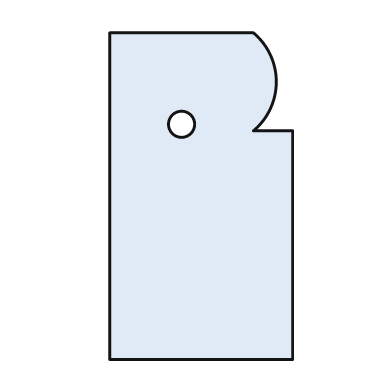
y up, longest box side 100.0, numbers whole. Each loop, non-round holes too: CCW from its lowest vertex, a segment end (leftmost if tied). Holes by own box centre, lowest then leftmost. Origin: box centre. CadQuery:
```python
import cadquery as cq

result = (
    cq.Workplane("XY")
    .moveTo(-28.0, -50.0)
    .lineTo(28.0, -50.0)
    .lineTo(28.0, 20.0)
    .lineTo(16.0, 20.0)
    .threePointArc((23.0, 35.0), (16.0, 50.0))
    .lineTo(-28.0, 50.0)
    .close()
    .moveTo(-6.0, 22.0)
    .circle(4.0)
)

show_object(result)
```